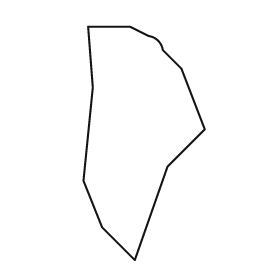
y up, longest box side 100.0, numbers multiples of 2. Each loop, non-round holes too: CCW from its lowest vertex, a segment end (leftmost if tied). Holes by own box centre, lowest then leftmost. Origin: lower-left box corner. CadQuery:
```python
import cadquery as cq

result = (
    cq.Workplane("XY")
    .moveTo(22.0, 0.0)
    .lineTo(36.0, 40.0)
    .lineTo(52.0, 56.0)
    .lineTo(42.0, 82.0)
    .lineTo(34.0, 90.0)
    .threePointArc((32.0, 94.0), (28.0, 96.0))
    .lineTo(20.0, 100.0)
    .lineTo(2.0, 100.0)
    .lineTo(4.0, 74.0)
    .lineTo(0.0, 34.0)
    .lineTo(8.0, 14.0)
    .close()
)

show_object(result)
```